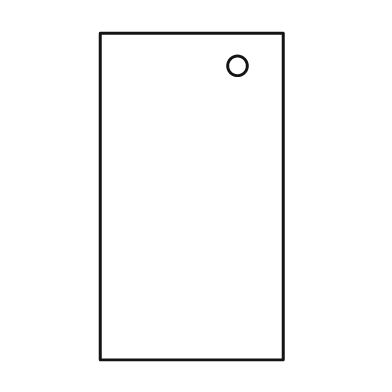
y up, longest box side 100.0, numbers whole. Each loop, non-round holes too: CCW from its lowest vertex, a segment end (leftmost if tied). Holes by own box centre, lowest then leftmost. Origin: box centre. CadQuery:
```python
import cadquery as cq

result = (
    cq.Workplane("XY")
    .moveTo(-28.0, -50.0)
    .lineTo(28.0, -50.0)
    .lineTo(28.0, 50.0)
    .lineTo(-28.0, 50.0)
    .close()
    .moveTo(14.0, 40.0)
    .circle(3.0)
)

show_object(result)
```